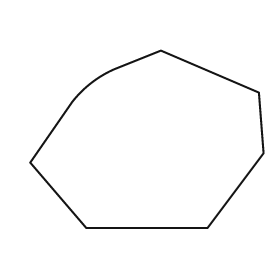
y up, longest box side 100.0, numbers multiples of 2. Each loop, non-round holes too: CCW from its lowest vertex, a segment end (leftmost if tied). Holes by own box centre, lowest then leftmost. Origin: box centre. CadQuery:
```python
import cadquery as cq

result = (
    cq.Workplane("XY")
    .moveTo(-26.0, -38.0)
    .lineTo(26.0, -38.0)
    .lineTo(50.0, -6.0)
    .lineTo(48.0, 20.0)
    .lineTo(6.0, 38.0)
    .lineTo(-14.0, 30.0)
    .threePointArc((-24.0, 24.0), (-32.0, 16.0))
    .lineTo(-50.0, -10.0)
    .close()
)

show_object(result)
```